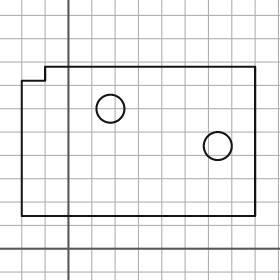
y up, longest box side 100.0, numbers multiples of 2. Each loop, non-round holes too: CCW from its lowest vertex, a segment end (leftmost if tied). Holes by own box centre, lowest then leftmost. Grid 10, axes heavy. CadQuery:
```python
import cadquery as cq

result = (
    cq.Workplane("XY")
    .moveTo(-20.0, 14.0)
    .lineTo(80.0, 14.0)
    .lineTo(80.0, 78.0)
    .lineTo(-10.0, 78.0)
    .lineTo(-10.0, 72.0)
    .lineTo(-20.0, 72.0)
    .close()
    .moveTo(64.0, 44.0)
    .circle(6.0)
    .moveTo(18.0, 60.0)
    .circle(6.0)
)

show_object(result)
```